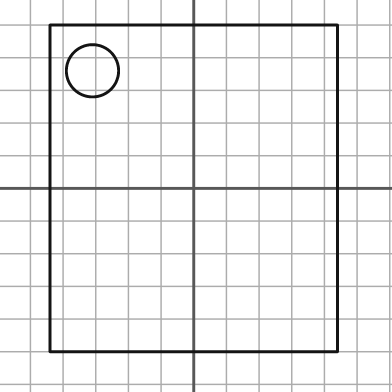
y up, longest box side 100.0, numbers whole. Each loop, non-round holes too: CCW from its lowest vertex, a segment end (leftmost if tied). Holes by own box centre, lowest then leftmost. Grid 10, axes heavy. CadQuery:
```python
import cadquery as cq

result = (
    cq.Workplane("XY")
    .moveTo(-44.0, -50.0)
    .lineTo(44.0, -50.0)
    .lineTo(44.0, 50.0)
    .lineTo(-44.0, 50.0)
    .close()
    .moveTo(-31.0, 36.0)
    .circle(8.0)
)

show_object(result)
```